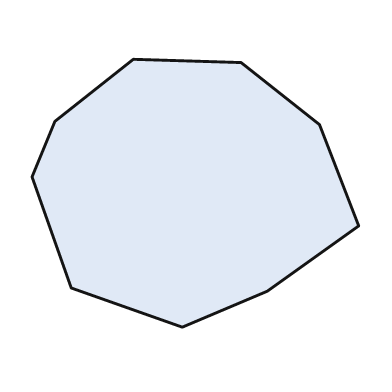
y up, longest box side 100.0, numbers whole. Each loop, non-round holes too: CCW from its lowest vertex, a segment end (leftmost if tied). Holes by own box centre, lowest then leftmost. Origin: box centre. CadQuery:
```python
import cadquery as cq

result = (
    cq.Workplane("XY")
    .moveTo(-4.0, -41.0)
    .lineTo(22.0, -30.0)
    .lineTo(50.0, -10.0)
    .lineTo(38.0, 21.0)
    .lineTo(14.0, 40.0)
    .lineTo(-19.0, 41.0)
    .lineTo(-43.0, 22.0)
    .lineTo(-50.0, 5.0)
    .lineTo(-38.0, -29.0)
    .close()
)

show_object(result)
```